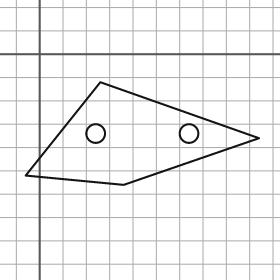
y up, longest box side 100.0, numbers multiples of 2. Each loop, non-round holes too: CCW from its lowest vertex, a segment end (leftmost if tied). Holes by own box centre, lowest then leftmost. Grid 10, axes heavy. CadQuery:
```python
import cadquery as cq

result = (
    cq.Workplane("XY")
    .moveTo(36.0, -56.0)
    .lineTo(94.0, -36.0)
    .lineTo(26.0, -12.0)
    .lineTo(-6.0, -52.0)
    .close()
    .moveTo(24.0, -34.0)
    .circle(4.0)
    .moveTo(64.0, -34.0)
    .circle(4.0)
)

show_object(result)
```